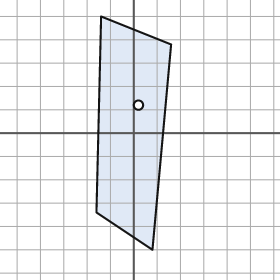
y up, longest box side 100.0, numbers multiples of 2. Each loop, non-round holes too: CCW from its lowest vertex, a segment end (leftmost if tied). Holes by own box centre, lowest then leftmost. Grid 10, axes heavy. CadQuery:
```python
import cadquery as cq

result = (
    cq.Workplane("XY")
    .moveTo(8.0, -50.0)
    .lineTo(16.0, 38.0)
    .lineTo(-14.0, 50.0)
    .lineTo(-16.0, -34.0)
    .close()
    .moveTo(2.0, 12.0)
    .circle(2.0)
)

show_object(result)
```